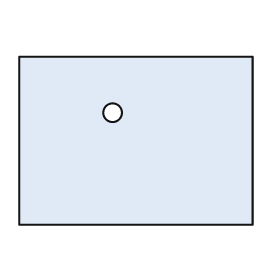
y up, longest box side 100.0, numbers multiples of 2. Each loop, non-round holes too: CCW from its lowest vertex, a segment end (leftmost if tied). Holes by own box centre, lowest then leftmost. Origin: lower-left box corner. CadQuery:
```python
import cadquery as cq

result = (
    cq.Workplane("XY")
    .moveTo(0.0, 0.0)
    .lineTo(100.0, 0.0)
    .lineTo(100.0, 72.0)
    .lineTo(0.0, 72.0)
    .close()
    .moveTo(40.0, 48.0)
    .circle(4.0)
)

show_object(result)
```